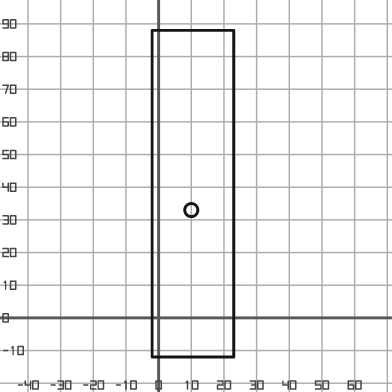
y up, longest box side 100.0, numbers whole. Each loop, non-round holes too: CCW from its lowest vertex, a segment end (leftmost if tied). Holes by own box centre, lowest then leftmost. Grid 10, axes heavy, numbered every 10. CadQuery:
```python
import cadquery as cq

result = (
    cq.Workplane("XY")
    .moveTo(-2.0, -12.0)
    .lineTo(23.0, -12.0)
    .lineTo(23.0, 88.0)
    .lineTo(-2.0, 88.0)
    .close()
    .moveTo(10.0, 33.0)
    .circle(2.0)
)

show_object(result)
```